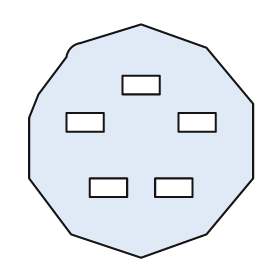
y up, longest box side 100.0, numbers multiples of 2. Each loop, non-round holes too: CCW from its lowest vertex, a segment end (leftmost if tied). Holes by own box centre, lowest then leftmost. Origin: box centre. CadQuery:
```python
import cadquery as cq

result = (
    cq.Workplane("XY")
    .moveTo(0.0, -50.0)
    .lineTo(28.0, -40.0)
    .lineTo(48.0, -16.0)
    .lineTo(48.0, 16.0)
    .lineTo(28.0, 40.0)
    .lineTo(0.0, 50.0)
    .lineTo(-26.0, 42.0)
    .threePointArc((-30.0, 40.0), (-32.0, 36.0))
    .lineTo(-44.0, 20.0)
    .lineTo(-48.0, 10.0)
    .lineTo(-48.0, -16.0)
    .lineTo(-30.0, -40.0)
    .close()
    .moveTo(-22.0, -24.0)
    .lineTo(-6.0, -24.0)
    .lineTo(-6.0, -16.0)
    .lineTo(-22.0, -16.0)
    .close()
    .moveTo(6.0, -24.0)
    .lineTo(22.0, -24.0)
    .lineTo(22.0, -16.0)
    .lineTo(6.0, -16.0)
    .close()
    .moveTo(-32.0, 4.0)
    .lineTo(-16.0, 4.0)
    .lineTo(-16.0, 12.0)
    .lineTo(-32.0, 12.0)
    .close()
    .moveTo(16.0, 4.0)
    .lineTo(32.0, 4.0)
    .lineTo(32.0, 12.0)
    .lineTo(16.0, 12.0)
    .close()
    .moveTo(-8.0, 20.0)
    .lineTo(8.0, 20.0)
    .lineTo(8.0, 28.0)
    .lineTo(-8.0, 28.0)
    .close()
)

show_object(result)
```